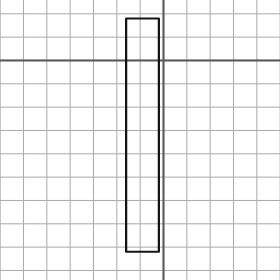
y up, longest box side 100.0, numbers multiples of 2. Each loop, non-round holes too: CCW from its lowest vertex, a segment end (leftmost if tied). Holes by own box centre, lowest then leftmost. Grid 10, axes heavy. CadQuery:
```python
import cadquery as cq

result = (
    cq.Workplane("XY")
    .moveTo(-16.0, -82.0)
    .lineTo(-2.0, -82.0)
    .lineTo(-2.0, 18.0)
    .lineTo(-16.0, 18.0)
    .close()
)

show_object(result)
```